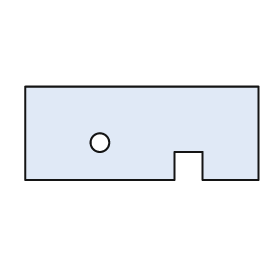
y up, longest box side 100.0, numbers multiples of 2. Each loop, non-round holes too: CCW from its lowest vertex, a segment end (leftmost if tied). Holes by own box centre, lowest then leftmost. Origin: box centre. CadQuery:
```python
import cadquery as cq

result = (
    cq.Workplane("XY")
    .moveTo(-50.0, -20.0)
    .lineTo(14.0, -20.0)
    .lineTo(14.0, -8.0)
    .lineTo(26.0, -8.0)
    .lineTo(26.0, -20.0)
    .lineTo(50.0, -20.0)
    .lineTo(50.0, 20.0)
    .lineTo(-50.0, 20.0)
    .close()
    .moveTo(-18.0, -4.0)
    .circle(4.0)
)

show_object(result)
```